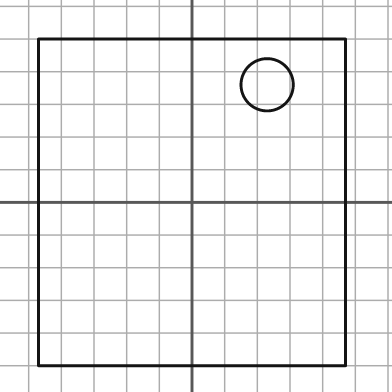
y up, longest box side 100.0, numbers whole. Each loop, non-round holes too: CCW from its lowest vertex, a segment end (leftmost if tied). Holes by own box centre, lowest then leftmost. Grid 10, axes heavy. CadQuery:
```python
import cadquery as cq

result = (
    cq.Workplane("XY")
    .moveTo(-47.0, -50.0)
    .lineTo(47.0, -50.0)
    .lineTo(47.0, 50.0)
    .lineTo(-47.0, 50.0)
    .close()
    .moveTo(23.0, 36.0)
    .circle(8.0)
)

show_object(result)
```